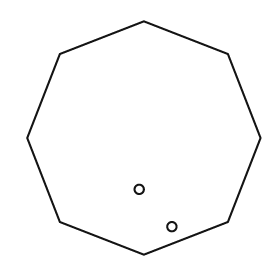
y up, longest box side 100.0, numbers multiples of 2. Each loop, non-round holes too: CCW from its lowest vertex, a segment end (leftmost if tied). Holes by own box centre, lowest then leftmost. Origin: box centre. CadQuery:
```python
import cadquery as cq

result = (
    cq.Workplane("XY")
    .moveTo(0.0, -50.0)
    .lineTo(36.0, -36.0)
    .lineTo(50.0, 0.0)
    .lineTo(36.0, 36.0)
    .lineTo(0.0, 50.0)
    .lineTo(-36.0, 36.0)
    .lineTo(-50.0, 0.0)
    .lineTo(-36.0, -36.0)
    .close()
    .moveTo(12.0, -38.0)
    .circle(2.0)
    .moveTo(-2.0, -22.0)
    .circle(2.0)
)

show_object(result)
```